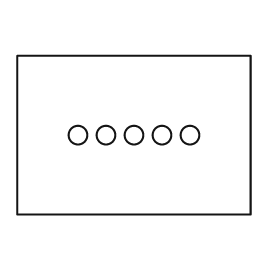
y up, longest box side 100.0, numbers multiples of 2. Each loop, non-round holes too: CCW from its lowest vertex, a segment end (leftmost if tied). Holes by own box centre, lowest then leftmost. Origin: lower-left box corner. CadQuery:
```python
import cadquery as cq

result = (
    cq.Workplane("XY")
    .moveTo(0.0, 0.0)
    .lineTo(100.0, 0.0)
    .lineTo(100.0, 68.0)
    .lineTo(0.0, 68.0)
    .close()
    .moveTo(26.0, 34.0)
    .circle(4.0)
    .moveTo(38.0, 34.0)
    .circle(4.0)
    .moveTo(50.0, 34.0)
    .circle(4.0)
    .moveTo(62.0, 34.0)
    .circle(4.0)
    .moveTo(74.0, 34.0)
    .circle(4.0)
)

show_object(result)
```